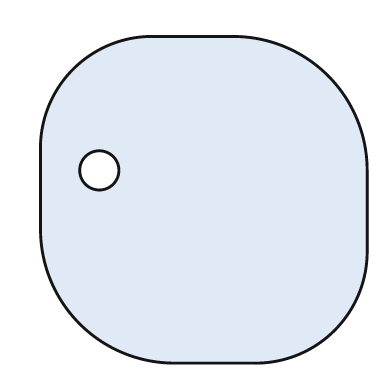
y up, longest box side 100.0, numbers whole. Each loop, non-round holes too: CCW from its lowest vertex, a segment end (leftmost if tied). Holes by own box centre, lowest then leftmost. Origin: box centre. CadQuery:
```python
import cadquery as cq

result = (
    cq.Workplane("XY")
    .moveTo(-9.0, -50.0)
    .lineTo(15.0, -50.0)
    .threePointArc((40.0, -40.0), (50.0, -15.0))
    .lineTo(50.0, 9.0)
    .threePointArc((38.0, 38.0), (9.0, 50.0))
    .lineTo(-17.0, 50.0)
    .threePointArc((-40.0, 40.0), (-50.0, 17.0))
    .lineTo(-50.0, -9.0)
    .threePointArc((-38.0, -38.0), (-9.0, -50.0))
    .close()
    .moveTo(-32.0, 9.0)
    .circle(6.0)
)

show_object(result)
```